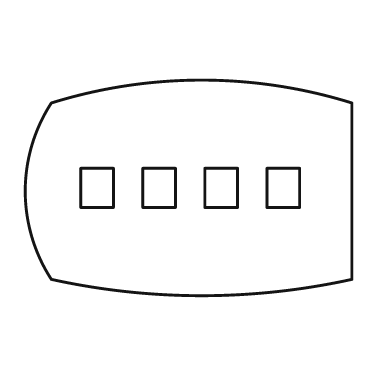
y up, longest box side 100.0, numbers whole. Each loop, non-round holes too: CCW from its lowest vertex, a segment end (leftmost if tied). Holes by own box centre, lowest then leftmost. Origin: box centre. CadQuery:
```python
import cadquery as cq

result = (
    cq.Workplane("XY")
    .moveTo(-42.0, -28.0)
    .threePointArc((4.0, -33.0), (50.0, -28.0))
    .lineTo(50.0, 26.0)
    .threePointArc((4.0, 33.0), (-42.0, 26.0))
    .threePointArc((-50.0, -1.0), (-42.0, -28.0))
    .close()
    .moveTo(-33.0, -6.0)
    .lineTo(-23.0, -6.0)
    .lineTo(-23.0, 6.0)
    .lineTo(-33.0, 6.0)
    .close()
    .moveTo(-14.0, -6.0)
    .lineTo(-4.0, -6.0)
    .lineTo(-4.0, 6.0)
    .lineTo(-14.0, 6.0)
    .close()
    .moveTo(5.0, -6.0)
    .lineTo(15.0, -6.0)
    .lineTo(15.0, 6.0)
    .lineTo(5.0, 6.0)
    .close()
    .moveTo(24.0, -6.0)
    .lineTo(34.0, -6.0)
    .lineTo(34.0, 6.0)
    .lineTo(24.0, 6.0)
    .close()
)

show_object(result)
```